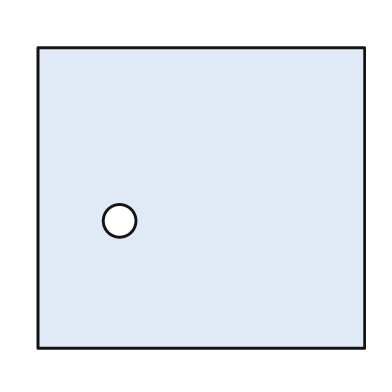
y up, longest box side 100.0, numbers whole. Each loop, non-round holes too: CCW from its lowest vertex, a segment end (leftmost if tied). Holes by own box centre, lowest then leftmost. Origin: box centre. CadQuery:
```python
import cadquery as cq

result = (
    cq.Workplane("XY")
    .moveTo(-50.0, -46.0)
    .lineTo(50.0, -46.0)
    .lineTo(50.0, 46.0)
    .lineTo(-50.0, 46.0)
    .close()
    .moveTo(-25.0, -7.0)
    .circle(5.0)
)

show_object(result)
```